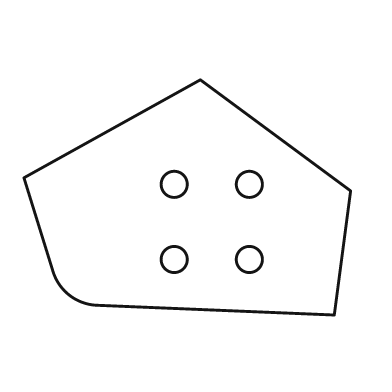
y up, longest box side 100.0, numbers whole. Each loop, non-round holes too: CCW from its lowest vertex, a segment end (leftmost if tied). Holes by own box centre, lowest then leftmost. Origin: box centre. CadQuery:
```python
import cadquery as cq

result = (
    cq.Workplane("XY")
    .moveTo(45.0, -36.0)
    .lineTo(50.0, 2.0)
    .lineTo(4.0, 36.0)
    .lineTo(-50.0, 6.0)
    .lineTo(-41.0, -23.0)
    .threePointArc((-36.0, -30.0), (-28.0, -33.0))
    .close()
    .moveTo(-4.0, -19.0)
    .circle(4.0)
    .moveTo(19.0, -19.0)
    .circle(4.0)
    .moveTo(-4.0, 4.0)
    .circle(4.0)
    .moveTo(19.0, 4.0)
    .circle(4.0)
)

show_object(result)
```